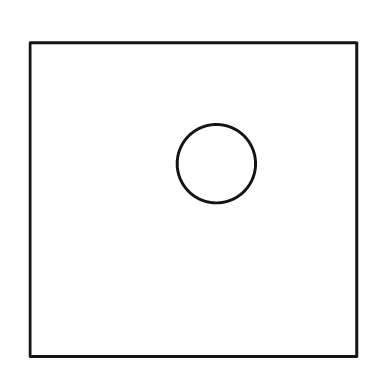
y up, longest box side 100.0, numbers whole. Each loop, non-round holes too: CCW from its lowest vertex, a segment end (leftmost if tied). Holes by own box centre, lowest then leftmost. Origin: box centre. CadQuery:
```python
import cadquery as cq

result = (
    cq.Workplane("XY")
    .moveTo(-50.0, -48.0)
    .lineTo(50.0, -48.0)
    .lineTo(50.0, 48.0)
    .lineTo(-50.0, 48.0)
    .close()
    .moveTo(7.0, 11.0)
    .circle(12.0)
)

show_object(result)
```